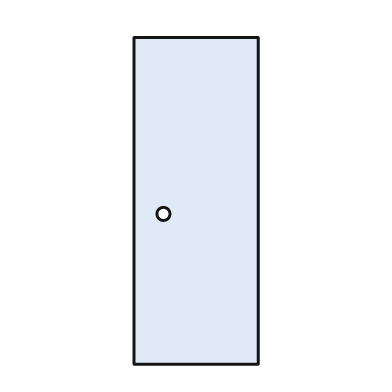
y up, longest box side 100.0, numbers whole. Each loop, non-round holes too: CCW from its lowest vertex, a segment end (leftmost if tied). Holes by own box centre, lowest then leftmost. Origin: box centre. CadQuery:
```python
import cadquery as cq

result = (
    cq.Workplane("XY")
    .moveTo(-19.0, -50.0)
    .lineTo(19.0, -50.0)
    .lineTo(19.0, 50.0)
    .lineTo(-19.0, 50.0)
    .close()
    .moveTo(-10.0, -4.0)
    .circle(2.0)
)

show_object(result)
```